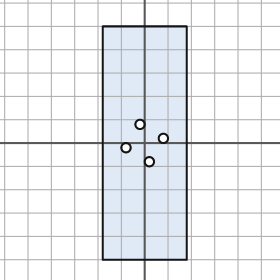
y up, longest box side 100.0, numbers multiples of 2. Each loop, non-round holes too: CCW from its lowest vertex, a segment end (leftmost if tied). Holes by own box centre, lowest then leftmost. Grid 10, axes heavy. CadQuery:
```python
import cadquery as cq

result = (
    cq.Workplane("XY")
    .moveTo(-18.0, -50.0)
    .lineTo(18.0, -50.0)
    .lineTo(18.0, 50.0)
    .lineTo(-18.0, 50.0)
    .close()
    .moveTo(2.0, -8.0)
    .circle(2.0)
    .moveTo(-8.0, -2.0)
    .circle(2.0)
    .moveTo(8.0, 2.0)
    .circle(2.0)
    .moveTo(-2.0, 8.0)
    .circle(2.0)
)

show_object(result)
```